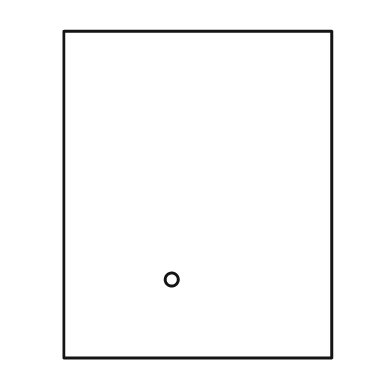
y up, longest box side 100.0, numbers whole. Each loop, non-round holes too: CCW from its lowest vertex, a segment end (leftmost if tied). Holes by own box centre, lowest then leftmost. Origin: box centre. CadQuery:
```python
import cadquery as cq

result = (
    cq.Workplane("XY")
    .moveTo(-41.0, -50.0)
    .lineTo(41.0, -50.0)
    .lineTo(41.0, 50.0)
    .lineTo(-41.0, 50.0)
    .close()
    .moveTo(-8.0, -26.0)
    .circle(2.0)
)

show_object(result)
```